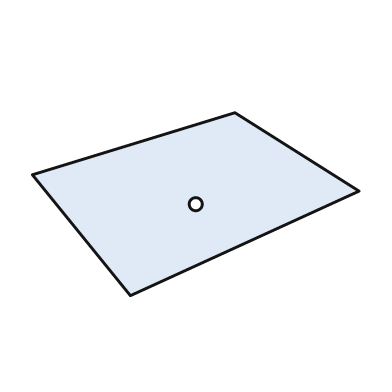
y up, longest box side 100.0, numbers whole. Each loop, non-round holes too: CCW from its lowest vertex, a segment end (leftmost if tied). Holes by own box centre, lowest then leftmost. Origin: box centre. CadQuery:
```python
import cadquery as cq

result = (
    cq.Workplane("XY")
    .moveTo(-20.0, -28.0)
    .lineTo(50.0, 4.0)
    .lineTo(12.0, 28.0)
    .lineTo(-50.0, 9.0)
    .close()
    .moveTo(0.0, 0.0)
    .circle(2.0)
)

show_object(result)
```